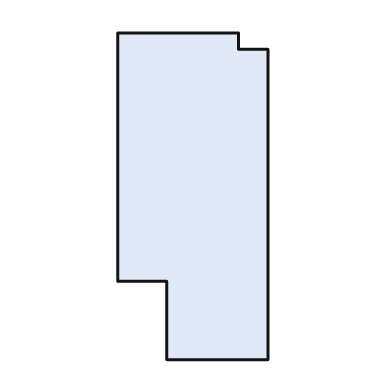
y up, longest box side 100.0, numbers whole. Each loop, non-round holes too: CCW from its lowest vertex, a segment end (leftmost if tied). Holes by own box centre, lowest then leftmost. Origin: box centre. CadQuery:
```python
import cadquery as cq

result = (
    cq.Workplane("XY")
    .moveTo(-8.0, -50.0)
    .lineTo(23.0, -50.0)
    .lineTo(23.0, 45.0)
    .lineTo(14.0, 45.0)
    .lineTo(14.0, 50.0)
    .lineTo(-23.0, 50.0)
    .lineTo(-23.0, -26.0)
    .lineTo(-8.0, -26.0)
    .close()
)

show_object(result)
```